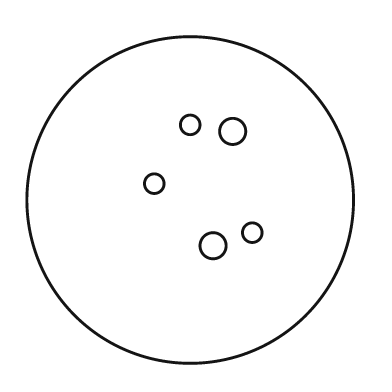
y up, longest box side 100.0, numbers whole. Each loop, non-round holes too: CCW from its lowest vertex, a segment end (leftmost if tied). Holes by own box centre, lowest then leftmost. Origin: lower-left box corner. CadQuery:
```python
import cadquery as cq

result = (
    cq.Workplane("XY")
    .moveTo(50.0, 50.0)
    .circle(50.0)
    .moveTo(57.0, 36.0)
    .circle(4.0)
    .moveTo(69.0, 40.0)
    .circle(3.0)
    .moveTo(39.0, 55.0)
    .circle(3.0)
    .moveTo(63.0, 71.0)
    .circle(4.0)
    .moveTo(50.0, 73.0)
    .circle(3.0)
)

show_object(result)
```